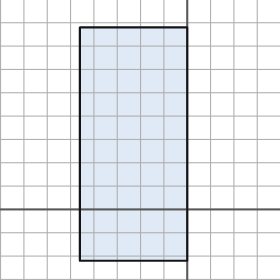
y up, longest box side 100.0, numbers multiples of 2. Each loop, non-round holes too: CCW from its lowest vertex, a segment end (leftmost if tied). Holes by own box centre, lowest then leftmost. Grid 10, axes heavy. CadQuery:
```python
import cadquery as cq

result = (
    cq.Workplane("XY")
    .moveTo(-46.0, -22.0)
    .lineTo(0.0, -22.0)
    .lineTo(0.0, 78.0)
    .lineTo(-46.0, 78.0)
    .close()
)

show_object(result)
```